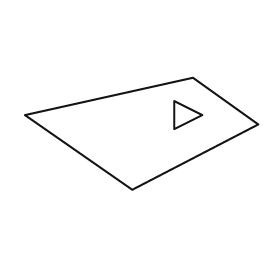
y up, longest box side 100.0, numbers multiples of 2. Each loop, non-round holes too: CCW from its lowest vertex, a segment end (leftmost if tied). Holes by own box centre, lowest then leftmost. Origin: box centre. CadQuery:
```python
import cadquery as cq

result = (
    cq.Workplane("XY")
    .moveTo(-4.0, -24.0)
    .lineTo(50.0, 4.0)
    .lineTo(22.0, 24.0)
    .lineTo(-50.0, 8.0)
    .close()
    .moveTo(14.0, 2.0)
    .lineTo(26.0, 8.0)
    .lineTo(14.0, 14.0)
    .close()
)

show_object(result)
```